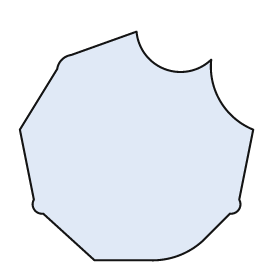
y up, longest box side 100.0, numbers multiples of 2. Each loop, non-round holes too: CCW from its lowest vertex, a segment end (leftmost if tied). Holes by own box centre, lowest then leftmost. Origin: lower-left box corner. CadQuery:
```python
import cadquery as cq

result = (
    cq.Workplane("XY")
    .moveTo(32.0, 0.0)
    .lineTo(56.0, 0.0)
    .threePointArc((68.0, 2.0), (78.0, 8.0))
    .lineTo(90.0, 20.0)
    .threePointArc((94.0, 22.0), (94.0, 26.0))
    .lineTo(100.0, 56.0)
    .threePointArc((86.0, 68.0), (82.0, 86.0))
    .threePointArc((62.0, 82.0), (50.0, 98.0))
    .lineTo(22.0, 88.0)
    .threePointArc((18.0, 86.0), (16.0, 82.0))
    .lineTo(0.0, 56.0)
    .lineTo(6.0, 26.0)
    .threePointArc((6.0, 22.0), (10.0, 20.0))
    .close()
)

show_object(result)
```